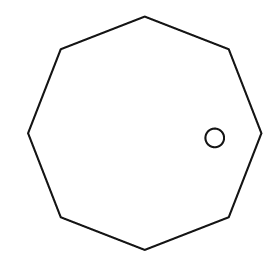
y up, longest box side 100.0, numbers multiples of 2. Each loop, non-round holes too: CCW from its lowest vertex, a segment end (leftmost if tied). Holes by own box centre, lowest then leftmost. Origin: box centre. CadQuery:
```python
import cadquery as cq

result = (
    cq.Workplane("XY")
    .moveTo(0.0, -50.0)
    .lineTo(36.0, -36.0)
    .lineTo(50.0, 0.0)
    .lineTo(36.0, 36.0)
    .lineTo(0.0, 50.0)
    .lineTo(-36.0, 36.0)
    .lineTo(-50.0, 0.0)
    .lineTo(-36.0, -36.0)
    .close()
    .moveTo(30.0, -2.0)
    .circle(4.0)
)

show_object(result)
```